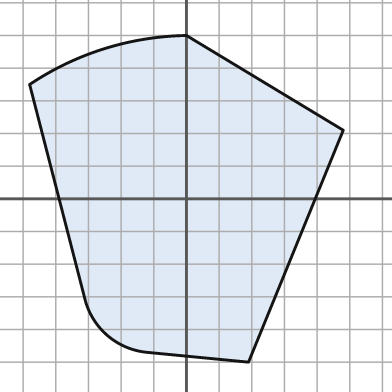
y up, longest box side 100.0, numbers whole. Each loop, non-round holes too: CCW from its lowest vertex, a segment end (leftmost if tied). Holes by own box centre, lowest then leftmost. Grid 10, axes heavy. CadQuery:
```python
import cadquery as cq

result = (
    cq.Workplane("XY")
    .moveTo(19.0, -50.0)
    .lineTo(48.0, 21.0)
    .lineTo(0.0, 50.0)
    .threePointArc((-25.0, 46.0), (-48.0, 35.0))
    .lineTo(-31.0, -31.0)
    .threePointArc((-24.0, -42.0), (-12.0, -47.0))
    .close()
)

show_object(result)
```